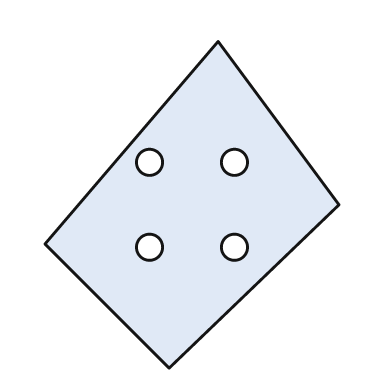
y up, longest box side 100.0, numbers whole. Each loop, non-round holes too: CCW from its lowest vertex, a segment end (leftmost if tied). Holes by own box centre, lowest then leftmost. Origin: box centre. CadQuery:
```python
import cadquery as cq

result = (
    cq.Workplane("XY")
    .moveTo(-7.0, -50.0)
    .lineTo(45.0, 0.0)
    .lineTo(8.0, 50.0)
    .lineTo(-45.0, -12.0)
    .close()
    .moveTo(-13.0, -13.0)
    .circle(4.0)
    .moveTo(13.0, -13.0)
    .circle(4.0)
    .moveTo(-13.0, 13.0)
    .circle(4.0)
    .moveTo(13.0, 13.0)
    .circle(4.0)
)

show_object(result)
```